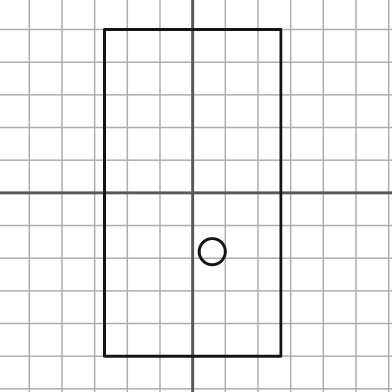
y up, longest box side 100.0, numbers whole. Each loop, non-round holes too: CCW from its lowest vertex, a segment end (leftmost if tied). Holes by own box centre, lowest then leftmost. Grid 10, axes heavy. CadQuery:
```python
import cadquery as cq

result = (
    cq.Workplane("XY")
    .moveTo(-27.0, -50.0)
    .lineTo(27.0, -50.0)
    .lineTo(27.0, 50.0)
    .lineTo(-27.0, 50.0)
    .close()
    .moveTo(6.0, -18.0)
    .circle(4.0)
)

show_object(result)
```